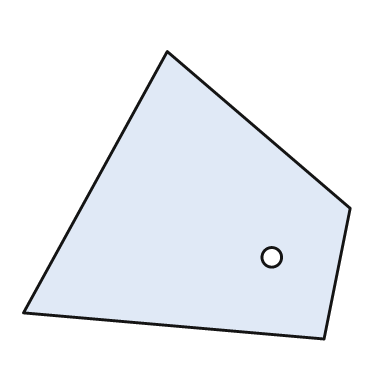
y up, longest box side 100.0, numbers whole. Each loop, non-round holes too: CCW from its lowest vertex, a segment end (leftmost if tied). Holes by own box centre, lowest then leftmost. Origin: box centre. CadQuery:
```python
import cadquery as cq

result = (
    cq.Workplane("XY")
    .moveTo(42.0, -44.0)
    .lineTo(50.0, -4.0)
    .lineTo(-6.0, 44.0)
    .lineTo(-50.0, -36.0)
    .close()
    .moveTo(26.0, -19.0)
    .circle(3.0)
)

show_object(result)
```